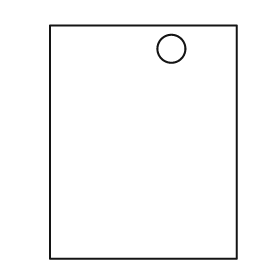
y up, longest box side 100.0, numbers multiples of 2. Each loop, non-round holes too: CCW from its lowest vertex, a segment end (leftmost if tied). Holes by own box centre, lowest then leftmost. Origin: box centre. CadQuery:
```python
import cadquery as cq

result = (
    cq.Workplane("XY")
    .moveTo(-40.0, -50.0)
    .lineTo(40.0, -50.0)
    .lineTo(40.0, 50.0)
    .lineTo(-40.0, 50.0)
    .close()
    .moveTo(12.0, 40.0)
    .circle(6.0)
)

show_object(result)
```